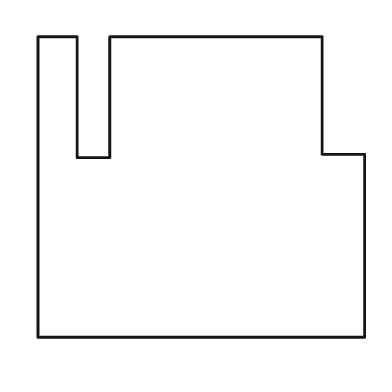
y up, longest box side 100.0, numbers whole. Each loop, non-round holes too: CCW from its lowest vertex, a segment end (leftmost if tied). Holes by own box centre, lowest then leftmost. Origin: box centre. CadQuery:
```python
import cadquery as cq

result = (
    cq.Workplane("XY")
    .moveTo(-50.0, -46.0)
    .lineTo(50.0, -46.0)
    .lineTo(50.0, 10.0)
    .lineTo(37.0, 10.0)
    .lineTo(37.0, 46.0)
    .lineTo(-28.0, 46.0)
    .lineTo(-28.0, 9.0)
    .lineTo(-38.0, 9.0)
    .lineTo(-38.0, 46.0)
    .lineTo(-50.0, 46.0)
    .close()
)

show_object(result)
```